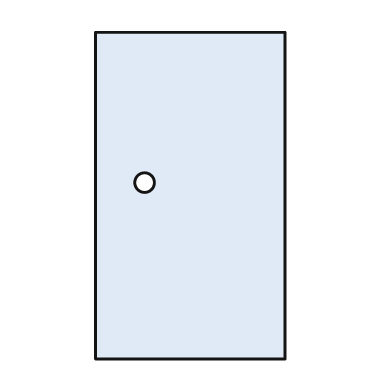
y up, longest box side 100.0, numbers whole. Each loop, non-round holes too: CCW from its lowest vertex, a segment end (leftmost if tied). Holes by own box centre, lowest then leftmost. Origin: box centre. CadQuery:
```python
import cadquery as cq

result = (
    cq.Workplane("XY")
    .moveTo(-29.0, -50.0)
    .lineTo(29.0, -50.0)
    .lineTo(29.0, 50.0)
    .lineTo(-29.0, 50.0)
    .close()
    .moveTo(-14.0, 4.0)
    .circle(3.0)
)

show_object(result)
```